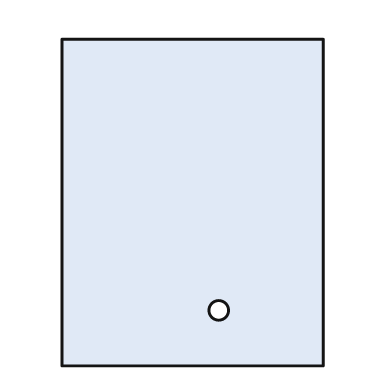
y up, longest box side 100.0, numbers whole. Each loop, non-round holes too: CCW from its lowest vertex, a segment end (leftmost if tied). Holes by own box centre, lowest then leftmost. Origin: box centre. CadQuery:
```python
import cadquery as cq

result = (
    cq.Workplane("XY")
    .moveTo(-40.0, -50.0)
    .lineTo(40.0, -50.0)
    .lineTo(40.0, 50.0)
    .lineTo(-40.0, 50.0)
    .close()
    .moveTo(8.0, -33.0)
    .circle(3.0)
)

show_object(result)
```